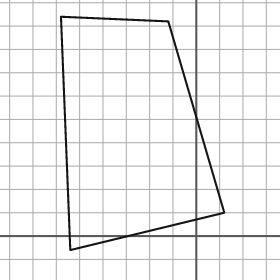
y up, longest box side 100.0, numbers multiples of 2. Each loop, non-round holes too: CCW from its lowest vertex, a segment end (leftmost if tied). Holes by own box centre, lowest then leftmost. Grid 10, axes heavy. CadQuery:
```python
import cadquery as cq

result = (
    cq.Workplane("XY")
    .moveTo(-54.0, -6.0)
    .lineTo(12.0, 10.0)
    .lineTo(-12.0, 92.0)
    .lineTo(-58.0, 94.0)
    .close()
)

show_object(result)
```